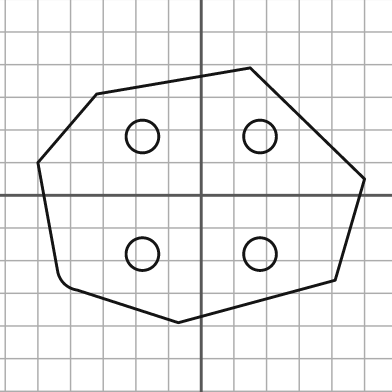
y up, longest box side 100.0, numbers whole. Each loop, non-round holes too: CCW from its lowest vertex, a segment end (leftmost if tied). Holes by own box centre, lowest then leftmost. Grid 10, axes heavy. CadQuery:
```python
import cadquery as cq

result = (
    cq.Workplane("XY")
    .moveTo(-7.0, -39.0)
    .lineTo(41.0, -26.0)
    .lineTo(50.0, 5.0)
    .lineTo(15.0, 39.0)
    .lineTo(-32.0, 31.0)
    .lineTo(-50.0, 10.0)
    .lineTo(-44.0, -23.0)
    .threePointArc((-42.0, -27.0), (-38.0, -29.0))
    .close()
    .moveTo(-18.0, -18.0)
    .circle(5.0)
    .moveTo(18.0, -18.0)
    .circle(5.0)
    .moveTo(-18.0, 18.0)
    .circle(5.0)
    .moveTo(18.0, 18.0)
    .circle(5.0)
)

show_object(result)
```